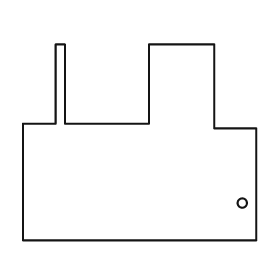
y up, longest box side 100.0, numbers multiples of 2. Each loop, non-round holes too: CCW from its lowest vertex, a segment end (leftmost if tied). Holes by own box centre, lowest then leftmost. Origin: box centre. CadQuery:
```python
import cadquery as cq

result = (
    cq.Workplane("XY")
    .moveTo(-50.0, -42.0)
    .lineTo(50.0, -42.0)
    .lineTo(50.0, 6.0)
    .lineTo(32.0, 6.0)
    .lineTo(32.0, 42.0)
    .lineTo(4.0, 42.0)
    .lineTo(4.0, 8.0)
    .lineTo(-32.0, 8.0)
    .lineTo(-32.0, 42.0)
    .lineTo(-36.0, 42.0)
    .lineTo(-36.0, 8.0)
    .lineTo(-50.0, 8.0)
    .close()
    .moveTo(44.0, -26.0)
    .circle(2.0)
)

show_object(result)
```